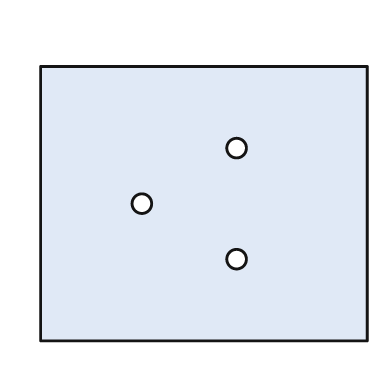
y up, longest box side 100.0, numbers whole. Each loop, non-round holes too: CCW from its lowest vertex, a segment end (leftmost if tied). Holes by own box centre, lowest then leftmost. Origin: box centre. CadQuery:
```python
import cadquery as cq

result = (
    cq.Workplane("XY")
    .moveTo(-50.0, -42.0)
    .lineTo(50.0, -42.0)
    .lineTo(50.0, 42.0)
    .lineTo(-50.0, 42.0)
    .close()
    .moveTo(10.0, -17.0)
    .circle(3.0)
    .moveTo(-19.0, 0.0)
    .circle(3.0)
    .moveTo(10.0, 17.0)
    .circle(3.0)
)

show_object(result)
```